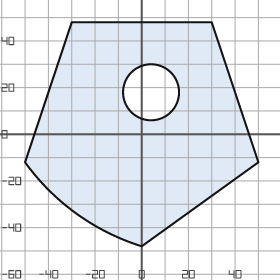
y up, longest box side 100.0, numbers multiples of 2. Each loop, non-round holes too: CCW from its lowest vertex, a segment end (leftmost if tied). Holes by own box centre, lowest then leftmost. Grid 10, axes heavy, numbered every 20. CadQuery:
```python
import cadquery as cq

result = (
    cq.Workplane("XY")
    .moveTo(0.0, -48.0)
    .lineTo(50.0, -12.0)
    .lineTo(30.0, 48.0)
    .lineTo(-30.0, 48.0)
    .lineTo(-50.0, -12.0)
    .threePointArc((-28.0, -34.0), (0.0, -48.0))
    .close()
    .moveTo(4.0, 18.0)
    .circle(12.0)
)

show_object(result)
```